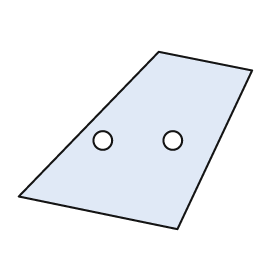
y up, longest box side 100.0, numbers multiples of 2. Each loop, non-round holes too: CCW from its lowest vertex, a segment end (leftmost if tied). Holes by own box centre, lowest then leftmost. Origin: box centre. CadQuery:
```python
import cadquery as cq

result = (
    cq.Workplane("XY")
    .moveTo(18.0, -38.0)
    .lineTo(50.0, 30.0)
    .lineTo(10.0, 38.0)
    .lineTo(-50.0, -24.0)
    .close()
    .moveTo(-14.0, 0.0)
    .circle(4.0)
    .moveTo(16.0, 0.0)
    .circle(4.0)
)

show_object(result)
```